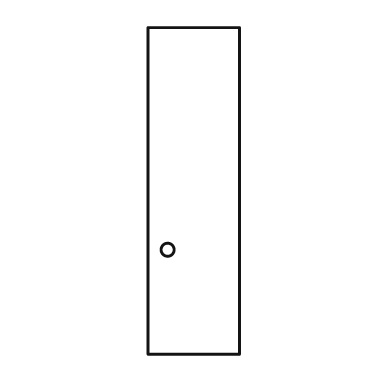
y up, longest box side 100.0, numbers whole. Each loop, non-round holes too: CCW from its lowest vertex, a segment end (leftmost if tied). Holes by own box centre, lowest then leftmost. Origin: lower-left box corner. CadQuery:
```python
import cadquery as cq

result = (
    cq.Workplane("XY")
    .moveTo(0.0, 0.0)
    .lineTo(28.0, 0.0)
    .lineTo(28.0, 100.0)
    .lineTo(0.0, 100.0)
    .close()
    .moveTo(6.0, 32.0)
    .circle(2.0)
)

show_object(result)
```